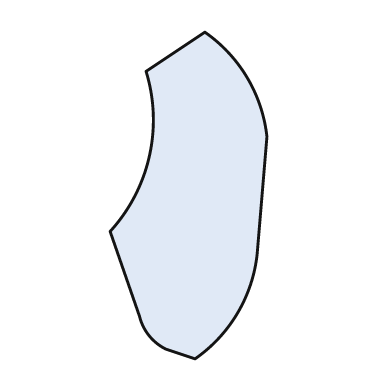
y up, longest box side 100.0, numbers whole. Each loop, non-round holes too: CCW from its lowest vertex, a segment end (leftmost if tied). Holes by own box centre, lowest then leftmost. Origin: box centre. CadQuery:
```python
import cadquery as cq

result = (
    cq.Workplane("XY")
    .moveTo(2.0, -50.0)
    .threePointArc((15.0, -36.0), (21.0, -18.0))
    .lineTo(24.0, 18.0)
    .threePointArc((18.0, 36.0), (5.0, 50.0))
    .lineTo(-13.0, 38.0)
    .threePointArc((-12.0, 12.0), (-24.0, -11.0))
    .lineTo(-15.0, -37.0)
    .threePointArc((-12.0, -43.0), (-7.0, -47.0))
    .close()
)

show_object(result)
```